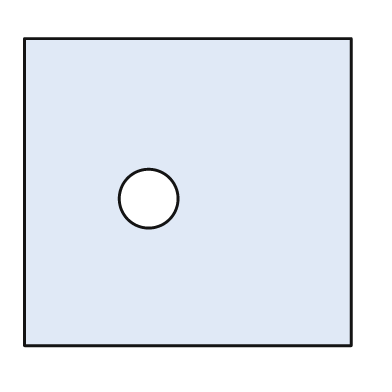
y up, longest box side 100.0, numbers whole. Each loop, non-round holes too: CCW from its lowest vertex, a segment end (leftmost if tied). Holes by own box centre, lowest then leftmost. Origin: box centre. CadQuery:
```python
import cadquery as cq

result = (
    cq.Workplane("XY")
    .moveTo(-50.0, -47.0)
    .lineTo(50.0, -47.0)
    .lineTo(50.0, 47.0)
    .lineTo(-50.0, 47.0)
    .close()
    .moveTo(-12.0, -2.0)
    .circle(9.0)
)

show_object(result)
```